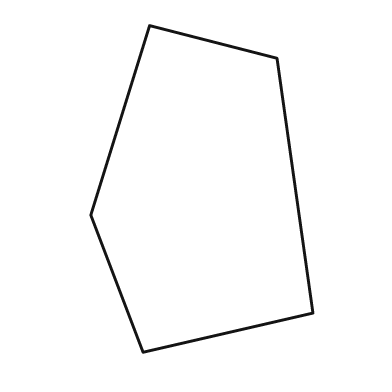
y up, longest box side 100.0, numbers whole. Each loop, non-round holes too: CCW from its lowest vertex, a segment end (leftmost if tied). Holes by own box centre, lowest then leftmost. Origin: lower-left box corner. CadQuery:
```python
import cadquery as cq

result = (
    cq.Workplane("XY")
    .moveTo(16.0, 0.0)
    .lineTo(68.0, 12.0)
    .lineTo(57.0, 90.0)
    .lineTo(18.0, 100.0)
    .lineTo(0.0, 42.0)
    .close()
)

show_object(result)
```